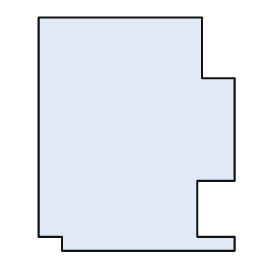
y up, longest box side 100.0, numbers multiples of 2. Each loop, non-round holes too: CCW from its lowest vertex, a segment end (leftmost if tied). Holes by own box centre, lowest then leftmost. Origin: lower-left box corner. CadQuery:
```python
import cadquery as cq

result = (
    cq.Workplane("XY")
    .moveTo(10.0, 0.0)
    .lineTo(84.0, 0.0)
    .lineTo(84.0, 6.0)
    .lineTo(68.0, 6.0)
    .lineTo(68.0, 30.0)
    .lineTo(84.0, 30.0)
    .lineTo(84.0, 74.0)
    .lineTo(70.0, 74.0)
    .lineTo(70.0, 100.0)
    .lineTo(0.0, 100.0)
    .lineTo(0.0, 6.0)
    .lineTo(10.0, 6.0)
    .close()
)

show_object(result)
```